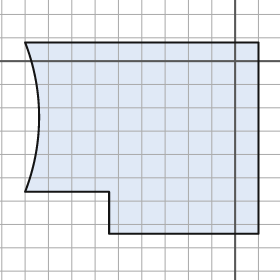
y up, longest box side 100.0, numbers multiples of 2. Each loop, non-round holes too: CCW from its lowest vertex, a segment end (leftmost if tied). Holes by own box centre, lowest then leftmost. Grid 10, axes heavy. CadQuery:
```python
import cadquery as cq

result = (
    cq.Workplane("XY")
    .moveTo(-54.0, -74.0)
    .lineTo(10.0, -74.0)
    .lineTo(10.0, 8.0)
    .lineTo(-90.0, 8.0)
    .threePointArc((-84.0, -24.0), (-90.0, -56.0))
    .lineTo(-54.0, -56.0)
    .close()
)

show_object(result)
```